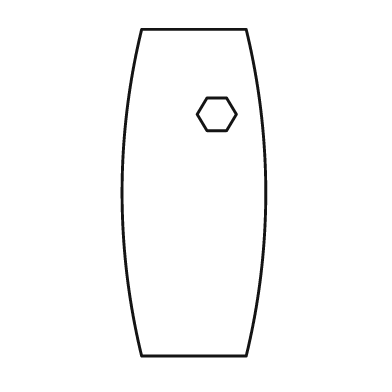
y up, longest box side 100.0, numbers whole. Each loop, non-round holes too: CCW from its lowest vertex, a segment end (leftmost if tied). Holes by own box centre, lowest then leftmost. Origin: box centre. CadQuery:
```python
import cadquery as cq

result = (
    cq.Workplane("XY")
    .moveTo(-16.0, -50.0)
    .lineTo(16.0, -50.0)
    .threePointArc((22.0, 0.0), (16.0, 50.0))
    .lineTo(-16.0, 50.0)
    .threePointArc((-22.0, 0.0), (-16.0, -50.0))
    .close()
    .moveTo(4.0, 19.0)
    .lineTo(10.0, 19.0)
    .lineTo(13.0, 24.0)
    .lineTo(10.0, 29.0)
    .lineTo(4.0, 29.0)
    .lineTo(1.0, 24.0)
    .close()
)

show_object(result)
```